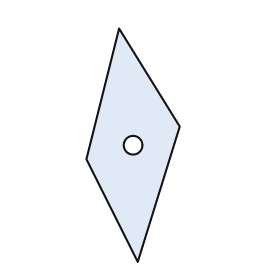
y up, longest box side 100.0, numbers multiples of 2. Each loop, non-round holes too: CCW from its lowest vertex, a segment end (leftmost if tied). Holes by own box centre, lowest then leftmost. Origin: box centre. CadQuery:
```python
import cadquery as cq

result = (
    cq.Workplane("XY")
    .moveTo(2.0, -50.0)
    .lineTo(20.0, 8.0)
    .lineTo(-6.0, 50.0)
    .lineTo(-20.0, -6.0)
    .close()
    .moveTo(0.0, 0.0)
    .circle(4.0)
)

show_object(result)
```